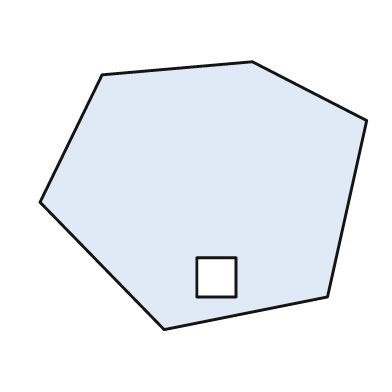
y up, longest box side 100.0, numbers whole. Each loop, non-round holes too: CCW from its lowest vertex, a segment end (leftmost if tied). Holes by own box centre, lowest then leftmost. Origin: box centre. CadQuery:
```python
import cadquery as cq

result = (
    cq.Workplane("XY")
    .moveTo(-12.0, -41.0)
    .lineTo(38.0, -31.0)
    .lineTo(50.0, 23.0)
    .lineTo(15.0, 41.0)
    .lineTo(-31.0, 37.0)
    .lineTo(-50.0, -2.0)
    .close()
    .moveTo(-2.0, -31.0)
    .lineTo(10.0, -31.0)
    .lineTo(10.0, -19.0)
    .lineTo(-2.0, -19.0)
    .close()
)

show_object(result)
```